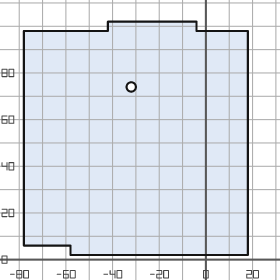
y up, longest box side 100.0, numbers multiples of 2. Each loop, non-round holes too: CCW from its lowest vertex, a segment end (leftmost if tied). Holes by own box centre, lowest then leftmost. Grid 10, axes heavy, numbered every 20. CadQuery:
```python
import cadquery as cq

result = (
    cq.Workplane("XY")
    .moveTo(-58.0, 2.0)
    .lineTo(18.0, 2.0)
    .lineTo(18.0, 98.0)
    .lineTo(-4.0, 98.0)
    .lineTo(-4.0, 102.0)
    .lineTo(-42.0, 102.0)
    .lineTo(-42.0, 98.0)
    .lineTo(-78.0, 98.0)
    .lineTo(-78.0, 6.0)
    .lineTo(-58.0, 6.0)
    .close()
    .moveTo(-32.0, 74.0)
    .circle(2.0)
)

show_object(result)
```